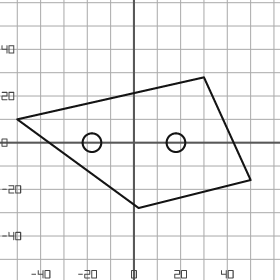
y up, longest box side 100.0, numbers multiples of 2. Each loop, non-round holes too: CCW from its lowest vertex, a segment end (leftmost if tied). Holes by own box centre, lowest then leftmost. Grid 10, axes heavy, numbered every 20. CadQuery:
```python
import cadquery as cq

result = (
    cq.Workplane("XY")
    .moveTo(2.0, -28.0)
    .lineTo(50.0, -16.0)
    .lineTo(30.0, 28.0)
    .lineTo(-50.0, 10.0)
    .close()
    .moveTo(-18.0, 0.0)
    .circle(4.0)
    .moveTo(18.0, 0.0)
    .circle(4.0)
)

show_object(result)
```